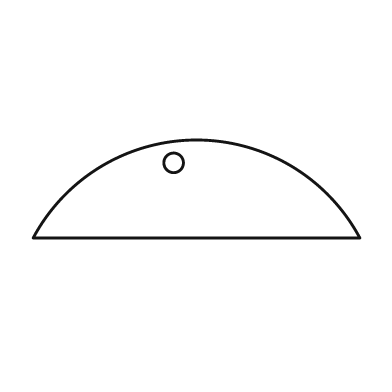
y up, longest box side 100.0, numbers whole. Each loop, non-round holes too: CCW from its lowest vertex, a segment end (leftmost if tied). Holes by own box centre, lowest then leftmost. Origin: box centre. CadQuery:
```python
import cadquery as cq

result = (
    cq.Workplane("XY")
    .moveTo(-50.0, -15.0)
    .lineTo(50.0, -15.0)
    .threePointArc((0.0, 15.0), (-50.0, -15.0))
    .close()
    .moveTo(-7.0, 8.0)
    .circle(3.0)
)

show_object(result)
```